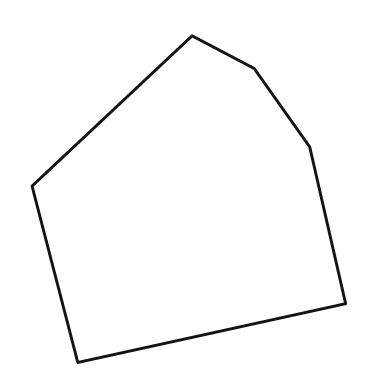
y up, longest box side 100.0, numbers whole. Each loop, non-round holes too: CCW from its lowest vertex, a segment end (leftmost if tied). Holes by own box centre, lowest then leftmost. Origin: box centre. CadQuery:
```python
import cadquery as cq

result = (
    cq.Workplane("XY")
    .moveTo(-34.0, -50.0)
    .lineTo(48.0, -32.0)
    .lineTo(37.0, 16.0)
    .lineTo(20.0, 40.0)
    .lineTo(1.0, 50.0)
    .lineTo(-48.0, 4.0)
    .close()
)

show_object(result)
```